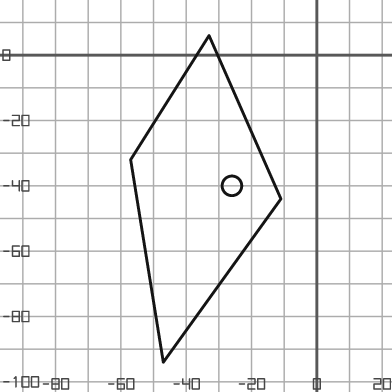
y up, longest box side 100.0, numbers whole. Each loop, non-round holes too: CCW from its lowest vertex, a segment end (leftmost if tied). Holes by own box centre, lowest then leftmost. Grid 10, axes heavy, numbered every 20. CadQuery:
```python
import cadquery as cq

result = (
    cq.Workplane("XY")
    .moveTo(-47.0, -94.0)
    .lineTo(-11.0, -44.0)
    .lineTo(-33.0, 6.0)
    .lineTo(-57.0, -32.0)
    .close()
    .moveTo(-26.0, -40.0)
    .circle(3.0)
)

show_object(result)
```